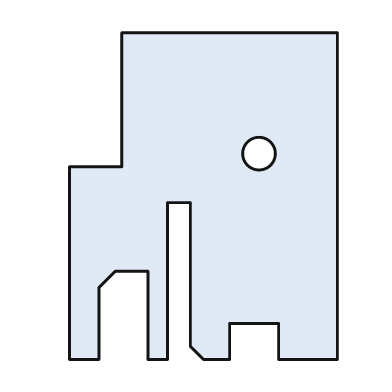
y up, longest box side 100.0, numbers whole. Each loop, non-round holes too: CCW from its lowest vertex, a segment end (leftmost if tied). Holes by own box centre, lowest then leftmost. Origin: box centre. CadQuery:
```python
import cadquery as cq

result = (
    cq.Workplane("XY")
    .moveTo(-41.0, -50.0)
    .lineTo(-32.0, -50.0)
    .lineTo(-32.0, -28.0)
    .lineTo(-27.0, -23.0)
    .lineTo(-17.0, -23.0)
    .lineTo(-17.0, -50.0)
    .lineTo(-11.0, -50.0)
    .lineTo(-11.0, -2.0)
    .lineTo(-4.0, -2.0)
    .lineTo(-4.0, -46.0)
    .lineTo(0.0, -50.0)
    .lineTo(8.0, -50.0)
    .lineTo(8.0, -39.0)
    .lineTo(23.0, -39.0)
    .lineTo(23.0, -50.0)
    .lineTo(41.0, -50.0)
    .lineTo(41.0, 50.0)
    .lineTo(-25.0, 50.0)
    .lineTo(-25.0, 9.0)
    .lineTo(-41.0, 9.0)
    .close()
    .moveTo(17.0, 13.0)
    .circle(5.0)
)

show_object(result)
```